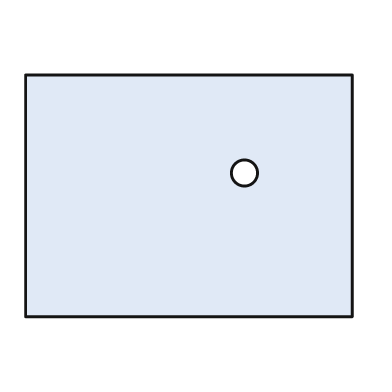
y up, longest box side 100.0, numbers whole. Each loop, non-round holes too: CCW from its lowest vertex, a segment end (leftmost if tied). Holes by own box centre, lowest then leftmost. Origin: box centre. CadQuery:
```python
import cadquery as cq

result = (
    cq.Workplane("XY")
    .moveTo(-50.0, -37.0)
    .lineTo(50.0, -37.0)
    .lineTo(50.0, 37.0)
    .lineTo(-50.0, 37.0)
    .close()
    .moveTo(17.0, 7.0)
    .circle(4.0)
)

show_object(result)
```